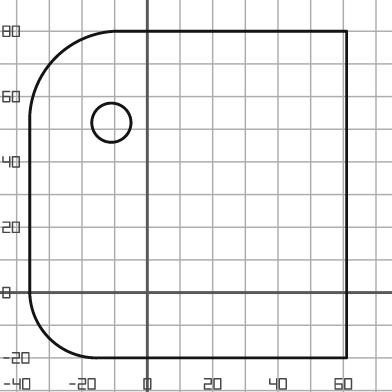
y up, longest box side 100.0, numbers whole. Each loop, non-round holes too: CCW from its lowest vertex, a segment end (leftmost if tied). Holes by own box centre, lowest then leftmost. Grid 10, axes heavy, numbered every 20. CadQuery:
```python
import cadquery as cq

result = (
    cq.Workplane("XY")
    .moveTo(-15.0, -20.0)
    .lineTo(61.0, -20.0)
    .lineTo(61.0, 80.0)
    .lineTo(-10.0, 80.0)
    .threePointArc((-28.0, 72.0), (-36.0, 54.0))
    .lineTo(-36.0, 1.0)
    .threePointArc((-30.0, -14.0), (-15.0, -20.0))
    .close()
    .moveTo(-11.0, 52.0)
    .circle(6.0)
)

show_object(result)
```